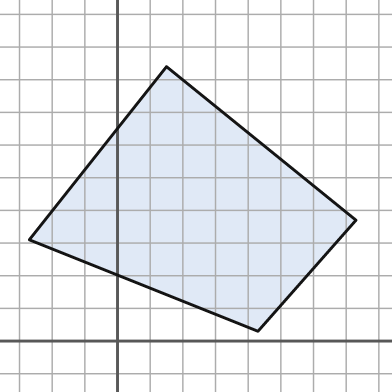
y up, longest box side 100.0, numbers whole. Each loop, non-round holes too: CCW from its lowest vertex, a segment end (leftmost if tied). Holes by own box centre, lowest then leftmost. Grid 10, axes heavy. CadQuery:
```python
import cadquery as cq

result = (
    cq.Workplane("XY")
    .moveTo(43.0, 3.0)
    .lineTo(73.0, 37.0)
    .lineTo(15.0, 84.0)
    .lineTo(-27.0, 31.0)
    .close()
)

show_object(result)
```